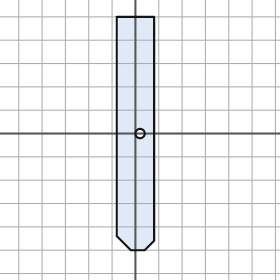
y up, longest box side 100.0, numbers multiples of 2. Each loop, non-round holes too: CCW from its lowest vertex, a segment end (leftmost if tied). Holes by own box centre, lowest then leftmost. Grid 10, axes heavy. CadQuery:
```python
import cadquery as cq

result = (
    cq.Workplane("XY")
    .moveTo(-2.0, -50.0)
    .lineTo(4.0, -50.0)
    .lineTo(8.0, -46.0)
    .lineTo(8.0, 50.0)
    .lineTo(-8.0, 50.0)
    .lineTo(-8.0, -44.0)
    .close()
    .moveTo(2.0, 0.0)
    .circle(2.0)
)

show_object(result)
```